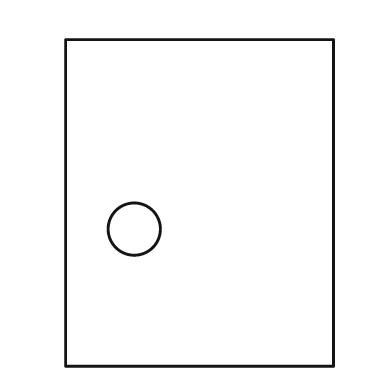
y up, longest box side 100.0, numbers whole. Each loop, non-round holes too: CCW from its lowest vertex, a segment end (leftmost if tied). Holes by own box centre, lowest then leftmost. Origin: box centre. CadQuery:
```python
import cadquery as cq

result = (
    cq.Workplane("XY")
    .moveTo(-41.0, -50.0)
    .lineTo(41.0, -50.0)
    .lineTo(41.0, 50.0)
    .lineTo(-41.0, 50.0)
    .close()
    .moveTo(-20.0, -8.0)
    .circle(8.0)
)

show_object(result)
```